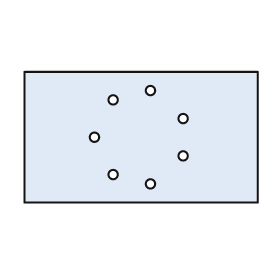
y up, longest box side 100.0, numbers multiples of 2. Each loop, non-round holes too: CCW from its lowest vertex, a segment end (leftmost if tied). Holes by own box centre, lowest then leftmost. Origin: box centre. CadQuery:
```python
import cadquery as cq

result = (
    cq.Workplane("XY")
    .moveTo(-50.0, -28.0)
    .lineTo(50.0, -28.0)
    .lineTo(50.0, 28.0)
    .lineTo(-50.0, 28.0)
    .close()
    .moveTo(4.0, -20.0)
    .circle(2.0)
    .moveTo(-12.0, -16.0)
    .circle(2.0)
    .moveTo(18.0, -8.0)
    .circle(2.0)
    .moveTo(-20.0, 0.0)
    .circle(2.0)
    .moveTo(18.0, 8.0)
    .circle(2.0)
    .moveTo(-12.0, 16.0)
    .circle(2.0)
    .moveTo(4.0, 20.0)
    .circle(2.0)
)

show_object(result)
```